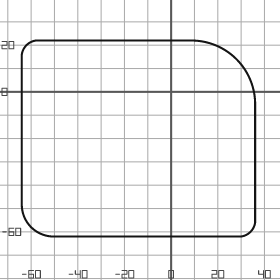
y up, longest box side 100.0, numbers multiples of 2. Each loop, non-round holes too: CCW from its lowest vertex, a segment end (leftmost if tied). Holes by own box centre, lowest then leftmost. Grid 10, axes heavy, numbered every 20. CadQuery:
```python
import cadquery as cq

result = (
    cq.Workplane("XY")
    .moveTo(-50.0, -62.0)
    .lineTo(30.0, -62.0)
    .threePointArc((34.0, -60.0), (36.0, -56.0))
    .lineTo(36.0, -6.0)
    .threePointArc((28.0, 14.0), (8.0, 22.0))
    .lineTo(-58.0, 22.0)
    .threePointArc((-62.0, 20.0), (-64.0, 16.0))
    .lineTo(-64.0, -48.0)
    .threePointArc((-60.0, -58.0), (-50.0, -62.0))
    .close()
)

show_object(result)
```